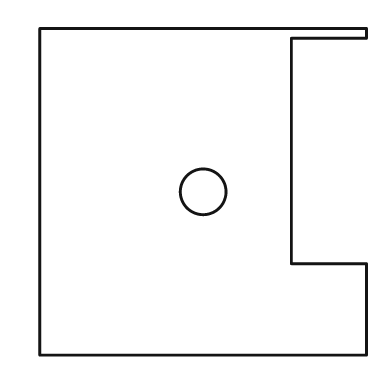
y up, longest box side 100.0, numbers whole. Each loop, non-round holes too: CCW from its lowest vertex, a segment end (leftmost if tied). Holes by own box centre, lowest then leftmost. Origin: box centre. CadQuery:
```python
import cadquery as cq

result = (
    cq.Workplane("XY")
    .moveTo(-50.0, -50.0)
    .lineTo(50.0, -50.0)
    .lineTo(50.0, -22.0)
    .lineTo(27.0, -22.0)
    .lineTo(27.0, 47.0)
    .lineTo(50.0, 47.0)
    .lineTo(50.0, 50.0)
    .lineTo(-50.0, 50.0)
    .close()
    .moveTo(0.0, 0.0)
    .circle(7.0)
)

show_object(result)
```